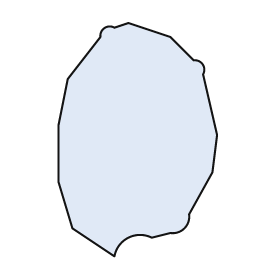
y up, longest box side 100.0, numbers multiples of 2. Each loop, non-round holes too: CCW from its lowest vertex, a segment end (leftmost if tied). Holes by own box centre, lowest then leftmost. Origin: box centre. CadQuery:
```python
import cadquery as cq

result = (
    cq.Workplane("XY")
    .moveTo(-10.0, -50.0)
    .threePointArc((-4.0, -42.0), (6.0, -42.0))
    .lineTo(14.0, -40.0)
    .threePointArc((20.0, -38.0), (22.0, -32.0))
    .lineTo(32.0, -14.0)
    .lineTo(34.0, 2.0)
    .lineTo(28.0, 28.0)
    .threePointArc((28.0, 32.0), (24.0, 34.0))
    .lineTo(14.0, 44.0)
    .lineTo(-4.0, 50.0)
    .lineTo(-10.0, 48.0)
    .threePointArc((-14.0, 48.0), (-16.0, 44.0))
    .lineTo(-30.0, 26.0)
    .lineTo(-34.0, 6.0)
    .lineTo(-34.0, -18.0)
    .lineTo(-28.0, -38.0)
    .close()
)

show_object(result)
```